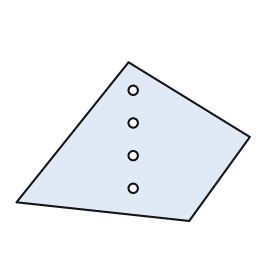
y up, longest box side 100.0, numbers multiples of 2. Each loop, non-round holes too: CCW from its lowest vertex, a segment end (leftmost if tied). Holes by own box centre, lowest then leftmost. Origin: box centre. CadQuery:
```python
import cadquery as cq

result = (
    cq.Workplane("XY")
    .moveTo(24.0, -34.0)
    .lineTo(50.0, 2.0)
    .lineTo(-2.0, 34.0)
    .lineTo(-50.0, -26.0)
    .close()
    .moveTo(0.0, -20.0)
    .circle(2.0)
    .moveTo(0.0, -6.0)
    .circle(2.0)
    .moveTo(0.0, 8.0)
    .circle(2.0)
    .moveTo(0.0, 22.0)
    .circle(2.0)
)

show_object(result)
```